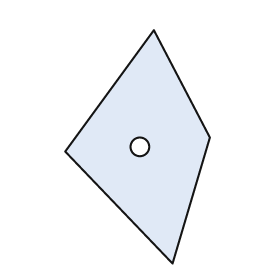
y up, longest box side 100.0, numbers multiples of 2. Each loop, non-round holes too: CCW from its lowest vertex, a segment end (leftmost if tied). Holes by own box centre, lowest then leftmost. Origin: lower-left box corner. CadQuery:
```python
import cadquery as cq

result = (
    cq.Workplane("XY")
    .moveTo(46.0, 0.0)
    .lineTo(62.0, 54.0)
    .lineTo(38.0, 100.0)
    .lineTo(0.0, 48.0)
    .close()
    .moveTo(32.0, 50.0)
    .circle(4.0)
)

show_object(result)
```